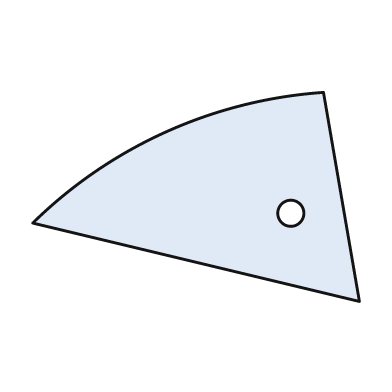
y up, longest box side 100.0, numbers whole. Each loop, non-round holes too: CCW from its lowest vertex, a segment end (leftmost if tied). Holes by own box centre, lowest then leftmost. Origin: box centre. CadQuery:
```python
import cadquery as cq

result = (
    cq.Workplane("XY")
    .moveTo(50.0, -32.0)
    .lineTo(39.0, 32.0)
    .threePointArc((-9.0, 20.0), (-50.0, -8.0))
    .close()
    .moveTo(29.0, -5.0)
    .circle(4.0)
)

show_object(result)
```